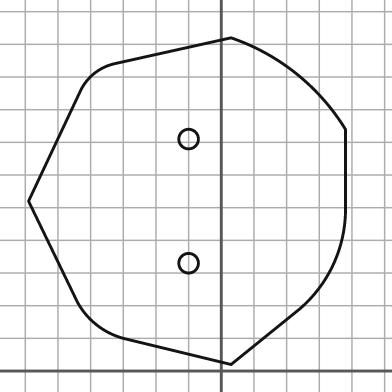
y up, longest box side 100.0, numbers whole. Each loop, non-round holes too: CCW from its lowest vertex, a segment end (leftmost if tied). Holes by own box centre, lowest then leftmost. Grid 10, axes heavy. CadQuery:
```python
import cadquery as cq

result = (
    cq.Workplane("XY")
    .moveTo(3.0, 2.0)
    .lineTo(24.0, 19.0)
    .threePointArc((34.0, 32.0), (38.0, 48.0))
    .lineTo(38.0, 74.0)
    .threePointArc((23.0, 91.0), (3.0, 102.0))
    .lineTo(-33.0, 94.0)
    .threePointArc((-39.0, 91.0), (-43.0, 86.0))
    .lineTo(-59.0, 52.0)
    .lineTo(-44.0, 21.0)
    .threePointArc((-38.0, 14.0), (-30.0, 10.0))
    .close()
    .moveTo(-10.0, 33.0)
    .circle(3.0)
    .moveTo(-10.0, 71.0)
    .circle(3.0)
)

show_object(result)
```